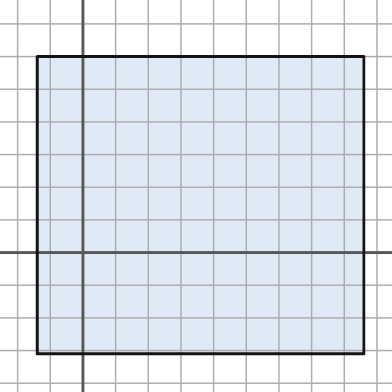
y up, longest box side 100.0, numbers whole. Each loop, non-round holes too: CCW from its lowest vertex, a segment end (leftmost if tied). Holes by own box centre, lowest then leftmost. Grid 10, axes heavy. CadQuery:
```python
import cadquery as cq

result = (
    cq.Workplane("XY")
    .moveTo(-14.0, -31.0)
    .lineTo(86.0, -31.0)
    .lineTo(86.0, 60.0)
    .lineTo(-14.0, 60.0)
    .close()
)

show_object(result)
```